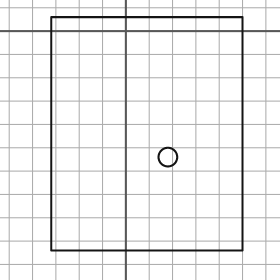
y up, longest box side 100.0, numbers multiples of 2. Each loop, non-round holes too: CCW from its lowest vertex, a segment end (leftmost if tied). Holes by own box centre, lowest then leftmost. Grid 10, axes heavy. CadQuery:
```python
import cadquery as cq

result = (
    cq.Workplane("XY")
    .moveTo(-32.0, -94.0)
    .lineTo(50.0, -94.0)
    .lineTo(50.0, 6.0)
    .lineTo(-32.0, 6.0)
    .close()
    .moveTo(18.0, -54.0)
    .circle(4.0)
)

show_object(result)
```